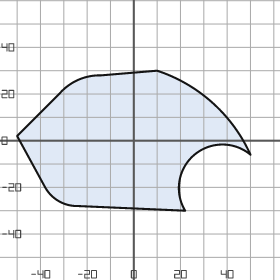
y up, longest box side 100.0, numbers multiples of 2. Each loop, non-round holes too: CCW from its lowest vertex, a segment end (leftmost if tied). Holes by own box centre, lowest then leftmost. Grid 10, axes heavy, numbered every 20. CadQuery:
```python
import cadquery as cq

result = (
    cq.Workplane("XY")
    .moveTo(22.0, -30.0)
    .threePointArc((26.0, -6.0), (50.0, -6.0))
    .threePointArc((34.0, 16.0), (10.0, 30.0))
    .lineTo(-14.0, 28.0)
    .threePointArc((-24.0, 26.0), (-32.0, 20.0))
    .lineTo(-50.0, 2.0)
    .lineTo(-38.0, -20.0)
    .threePointArc((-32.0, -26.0), (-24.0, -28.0))
    .close()
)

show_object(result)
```